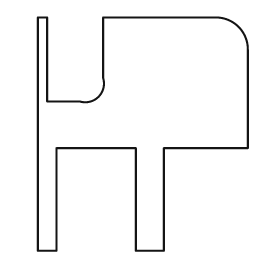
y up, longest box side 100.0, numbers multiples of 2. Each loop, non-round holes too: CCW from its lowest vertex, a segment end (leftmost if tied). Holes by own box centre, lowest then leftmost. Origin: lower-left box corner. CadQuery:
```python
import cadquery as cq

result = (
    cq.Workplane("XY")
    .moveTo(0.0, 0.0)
    .lineTo(8.0, 0.0)
    .lineTo(8.0, 44.0)
    .lineTo(42.0, 44.0)
    .lineTo(42.0, 0.0)
    .lineTo(54.0, 0.0)
    .lineTo(54.0, 44.0)
    .lineTo(90.0, 44.0)
    .lineTo(90.0, 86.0)
    .threePointArc((86.0, 96.0), (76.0, 100.0))
    .lineTo(28.0, 100.0)
    .lineTo(28.0, 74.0)
    .threePointArc((26.0, 66.0), (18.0, 64.0))
    .lineTo(4.0, 64.0)
    .lineTo(4.0, 100.0)
    .lineTo(0.0, 100.0)
    .close()
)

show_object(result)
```